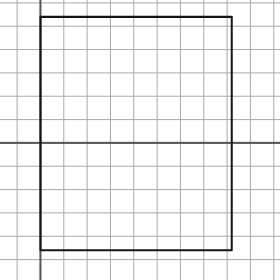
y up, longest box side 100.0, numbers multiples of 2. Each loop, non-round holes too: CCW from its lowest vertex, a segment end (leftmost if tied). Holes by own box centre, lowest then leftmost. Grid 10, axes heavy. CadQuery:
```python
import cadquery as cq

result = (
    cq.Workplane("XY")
    .moveTo(0.0, -46.0)
    .lineTo(82.0, -46.0)
    .lineTo(82.0, 54.0)
    .lineTo(0.0, 54.0)
    .close()
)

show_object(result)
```